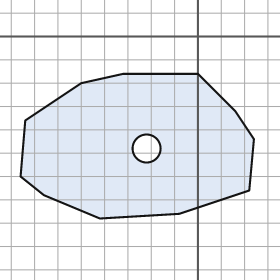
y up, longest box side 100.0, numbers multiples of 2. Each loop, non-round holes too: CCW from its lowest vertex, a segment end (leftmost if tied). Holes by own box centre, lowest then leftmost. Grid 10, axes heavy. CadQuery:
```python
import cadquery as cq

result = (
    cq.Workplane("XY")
    .moveTo(-42.0, -78.0)
    .lineTo(-8.0, -76.0)
    .lineTo(22.0, -66.0)
    .lineTo(24.0, -44.0)
    .lineTo(16.0, -32.0)
    .lineTo(0.0, -16.0)
    .lineTo(-32.0, -16.0)
    .lineTo(-50.0, -20.0)
    .lineTo(-74.0, -36.0)
    .lineTo(-76.0, -60.0)
    .lineTo(-66.0, -68.0)
    .close()
    .moveTo(-22.0, -48.0)
    .circle(6.0)
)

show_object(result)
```